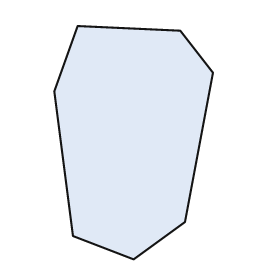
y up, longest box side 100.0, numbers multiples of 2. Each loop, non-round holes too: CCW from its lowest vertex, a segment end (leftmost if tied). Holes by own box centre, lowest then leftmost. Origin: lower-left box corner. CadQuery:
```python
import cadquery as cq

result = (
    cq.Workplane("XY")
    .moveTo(34.0, 0.0)
    .lineTo(56.0, 16.0)
    .lineTo(68.0, 80.0)
    .lineTo(54.0, 98.0)
    .lineTo(10.0, 100.0)
    .lineTo(0.0, 72.0)
    .lineTo(8.0, 10.0)
    .close()
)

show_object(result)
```